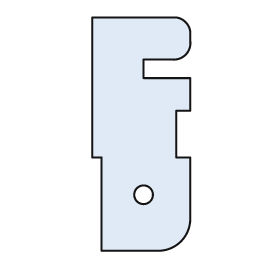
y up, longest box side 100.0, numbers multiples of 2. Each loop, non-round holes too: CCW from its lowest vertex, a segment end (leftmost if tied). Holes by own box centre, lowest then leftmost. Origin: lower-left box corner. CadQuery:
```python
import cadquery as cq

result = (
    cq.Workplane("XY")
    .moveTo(4.0, 0.0)
    .lineTo(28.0, 0.0)
    .threePointArc((38.0, 4.0), (42.0, 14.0))
    .lineTo(42.0, 40.0)
    .lineTo(36.0, 40.0)
    .lineTo(36.0, 60.0)
    .lineTo(42.0, 60.0)
    .lineTo(42.0, 74.0)
    .lineTo(22.0, 74.0)
    .lineTo(22.0, 82.0)
    .lineTo(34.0, 82.0)
    .threePointArc((40.0, 84.0), (42.0, 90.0))
    .lineTo(42.0, 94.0)
    .threePointArc((40.0, 98.0), (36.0, 100.0))
    .lineTo(0.0, 100.0)
    .lineTo(0.0, 40.0)
    .lineTo(4.0, 40.0)
    .close()
    .moveTo(22.0, 24.0)
    .circle(4.0)
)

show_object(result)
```